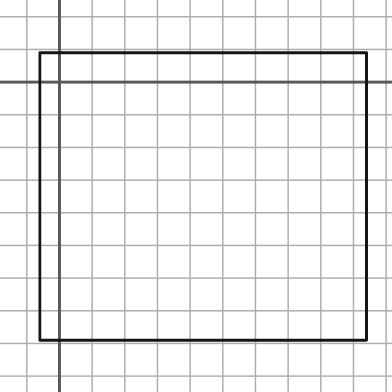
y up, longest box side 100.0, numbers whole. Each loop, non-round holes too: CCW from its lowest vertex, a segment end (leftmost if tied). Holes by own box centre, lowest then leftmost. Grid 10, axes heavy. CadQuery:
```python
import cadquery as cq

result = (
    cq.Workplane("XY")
    .moveTo(-6.0, -79.0)
    .lineTo(94.0, -79.0)
    .lineTo(94.0, 9.0)
    .lineTo(-6.0, 9.0)
    .close()
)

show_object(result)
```